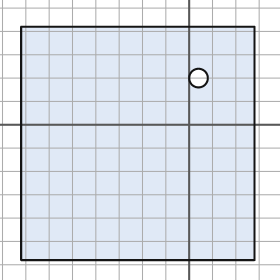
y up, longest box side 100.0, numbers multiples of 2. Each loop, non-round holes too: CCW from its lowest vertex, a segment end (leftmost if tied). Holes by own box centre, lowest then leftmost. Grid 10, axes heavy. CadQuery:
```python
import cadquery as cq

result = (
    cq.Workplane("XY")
    .moveTo(-72.0, -58.0)
    .lineTo(28.0, -58.0)
    .lineTo(28.0, 42.0)
    .lineTo(-72.0, 42.0)
    .close()
    .moveTo(4.0, 20.0)
    .circle(4.0)
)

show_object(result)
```